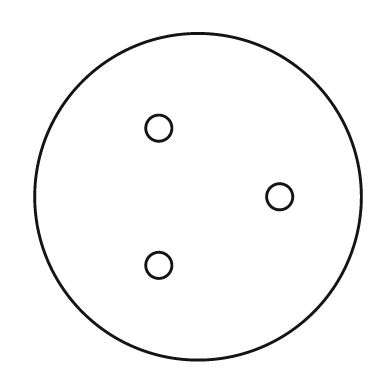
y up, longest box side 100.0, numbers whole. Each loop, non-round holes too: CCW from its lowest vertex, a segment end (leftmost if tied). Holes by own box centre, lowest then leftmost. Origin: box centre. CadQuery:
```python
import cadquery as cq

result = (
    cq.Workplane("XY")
    .moveTo(0.0, 0.0)
    .circle(50.0)
    .moveTo(-12.0, -21.0)
    .circle(4.0)
    .moveTo(25.0, 0.0)
    .circle(4.0)
    .moveTo(-12.0, 21.0)
    .circle(4.0)
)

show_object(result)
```